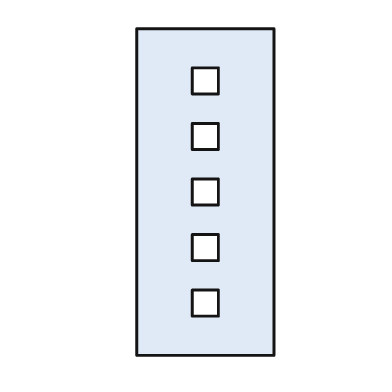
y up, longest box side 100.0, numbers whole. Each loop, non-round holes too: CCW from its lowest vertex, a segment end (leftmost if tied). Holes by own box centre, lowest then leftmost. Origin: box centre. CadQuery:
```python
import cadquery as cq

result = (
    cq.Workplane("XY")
    .moveTo(-21.0, -50.0)
    .lineTo(21.0, -50.0)
    .lineTo(21.0, 50.0)
    .lineTo(-21.0, 50.0)
    .close()
    .moveTo(-4.0, -38.0)
    .lineTo(4.0, -38.0)
    .lineTo(4.0, -30.0)
    .lineTo(-4.0, -30.0)
    .close()
    .moveTo(-4.0, -21.0)
    .lineTo(4.0, -21.0)
    .lineTo(4.0, -13.0)
    .lineTo(-4.0, -13.0)
    .close()
    .moveTo(-4.0, -4.0)
    .lineTo(4.0, -4.0)
    .lineTo(4.0, 4.0)
    .lineTo(-4.0, 4.0)
    .close()
    .moveTo(-4.0, 13.0)
    .lineTo(4.0, 13.0)
    .lineTo(4.0, 21.0)
    .lineTo(-4.0, 21.0)
    .close()
    .moveTo(-4.0, 30.0)
    .lineTo(4.0, 30.0)
    .lineTo(4.0, 38.0)
    .lineTo(-4.0, 38.0)
    .close()
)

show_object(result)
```